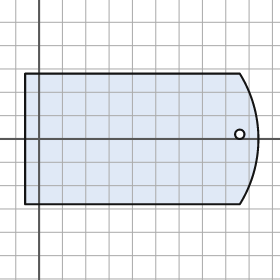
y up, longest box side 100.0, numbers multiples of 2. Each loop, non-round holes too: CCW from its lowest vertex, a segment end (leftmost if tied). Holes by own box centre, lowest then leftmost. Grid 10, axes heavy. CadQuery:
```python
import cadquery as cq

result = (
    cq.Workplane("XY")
    .moveTo(-6.0, -28.0)
    .lineTo(86.0, -28.0)
    .threePointArc((94.0, 0.0), (86.0, 28.0))
    .lineTo(-6.0, 28.0)
    .close()
    .moveTo(86.0, 2.0)
    .circle(2.0)
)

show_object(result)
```